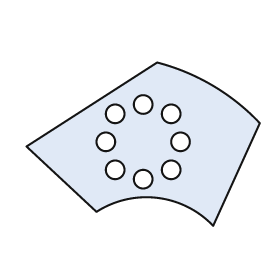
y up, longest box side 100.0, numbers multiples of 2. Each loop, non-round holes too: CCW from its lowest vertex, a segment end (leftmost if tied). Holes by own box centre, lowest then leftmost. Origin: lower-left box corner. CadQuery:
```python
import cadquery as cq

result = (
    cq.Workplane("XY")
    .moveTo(80.0, 0.0)
    .lineTo(100.0, 44.0)
    .threePointArc((80.0, 60.0), (56.0, 70.0))
    .lineTo(0.0, 34.0)
    .lineTo(30.0, 6.0)
    .threePointArc((56.0, 12.0), (80.0, 0.0))
    .close()
    .moveTo(50.0, 20.0)
    .circle(4.0)
    .moveTo(38.0, 24.0)
    .circle(4.0)
    .moveTo(62.0, 24.0)
    .circle(4.0)
    .moveTo(34.0, 36.0)
    .circle(4.0)
    .moveTo(66.0, 36.0)
    .circle(4.0)
    .moveTo(38.0, 48.0)
    .circle(4.0)
    .moveTo(62.0, 48.0)
    .circle(4.0)
    .moveTo(50.0, 52.0)
    .circle(4.0)
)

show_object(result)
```